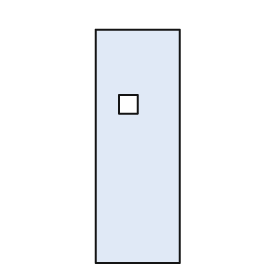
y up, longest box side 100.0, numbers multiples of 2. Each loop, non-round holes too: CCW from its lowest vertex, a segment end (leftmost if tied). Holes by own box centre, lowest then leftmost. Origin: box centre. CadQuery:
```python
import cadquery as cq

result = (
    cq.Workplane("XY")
    .moveTo(-18.0, -50.0)
    .lineTo(18.0, -50.0)
    .lineTo(18.0, 50.0)
    .lineTo(-18.0, 50.0)
    .close()
    .moveTo(-8.0, 14.0)
    .lineTo(0.0, 14.0)
    .lineTo(0.0, 22.0)
    .lineTo(-8.0, 22.0)
    .close()
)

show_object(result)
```